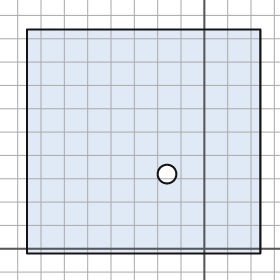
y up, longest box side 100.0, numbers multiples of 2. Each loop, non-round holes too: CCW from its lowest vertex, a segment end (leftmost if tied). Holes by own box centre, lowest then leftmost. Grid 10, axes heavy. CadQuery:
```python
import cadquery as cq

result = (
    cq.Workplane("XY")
    .moveTo(-76.0, -2.0)
    .lineTo(24.0, -2.0)
    .lineTo(24.0, 94.0)
    .lineTo(-76.0, 94.0)
    .close()
    .moveTo(-16.0, 32.0)
    .circle(4.0)
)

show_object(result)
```